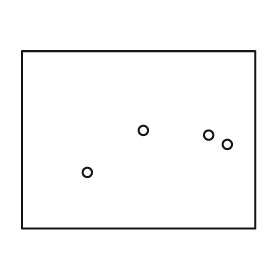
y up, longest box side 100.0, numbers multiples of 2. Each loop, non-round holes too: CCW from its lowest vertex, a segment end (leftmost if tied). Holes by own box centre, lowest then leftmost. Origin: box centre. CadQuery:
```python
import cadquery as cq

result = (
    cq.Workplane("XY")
    .moveTo(-50.0, -38.0)
    .lineTo(50.0, -38.0)
    .lineTo(50.0, 38.0)
    .lineTo(-50.0, 38.0)
    .close()
    .moveTo(-22.0, -14.0)
    .circle(2.0)
    .moveTo(38.0, -2.0)
    .circle(2.0)
    .moveTo(30.0, 2.0)
    .circle(2.0)
    .moveTo(2.0, 4.0)
    .circle(2.0)
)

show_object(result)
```